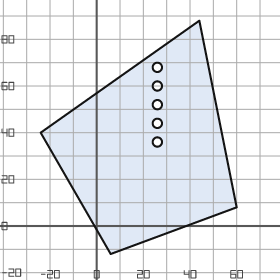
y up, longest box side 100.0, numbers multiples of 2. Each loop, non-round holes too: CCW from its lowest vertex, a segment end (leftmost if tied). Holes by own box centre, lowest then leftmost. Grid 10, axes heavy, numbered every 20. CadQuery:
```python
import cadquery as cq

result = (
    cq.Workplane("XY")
    .moveTo(6.0, -12.0)
    .lineTo(60.0, 8.0)
    .lineTo(44.0, 88.0)
    .lineTo(-24.0, 40.0)
    .close()
    .moveTo(26.0, 36.0)
    .circle(2.0)
    .moveTo(26.0, 44.0)
    .circle(2.0)
    .moveTo(26.0, 52.0)
    .circle(2.0)
    .moveTo(26.0, 60.0)
    .circle(2.0)
    .moveTo(26.0, 68.0)
    .circle(2.0)
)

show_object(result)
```